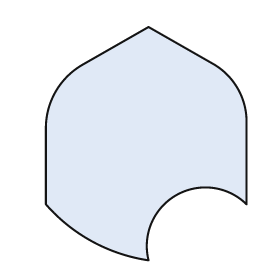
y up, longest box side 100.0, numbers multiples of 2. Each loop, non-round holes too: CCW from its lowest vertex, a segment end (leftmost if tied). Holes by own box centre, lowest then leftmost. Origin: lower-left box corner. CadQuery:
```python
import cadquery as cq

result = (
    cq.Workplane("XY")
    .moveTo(44.0, 0.0)
    .threePointArc((56.0, 28.0), (86.0, 24.0))
    .lineTo(86.0, 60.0)
    .threePointArc((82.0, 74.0), (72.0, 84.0))
    .lineTo(44.0, 100.0)
    .lineTo(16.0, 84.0)
    .threePointArc((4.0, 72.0), (0.0, 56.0))
    .lineTo(0.0, 24.0)
    .threePointArc((20.0, 8.0), (44.0, 0.0))
    .close()
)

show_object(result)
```